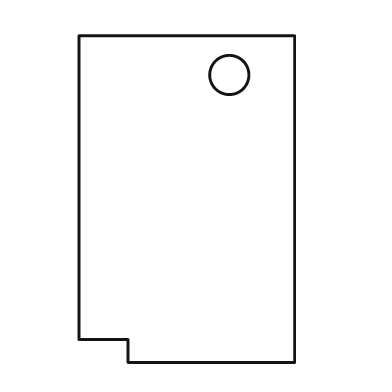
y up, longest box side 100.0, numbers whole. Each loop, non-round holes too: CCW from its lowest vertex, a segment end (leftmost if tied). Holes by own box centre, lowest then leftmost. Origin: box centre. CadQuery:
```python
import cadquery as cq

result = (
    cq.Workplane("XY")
    .moveTo(-18.0, -50.0)
    .lineTo(33.0, -50.0)
    .lineTo(33.0, 50.0)
    .lineTo(-33.0, 50.0)
    .lineTo(-33.0, -43.0)
    .lineTo(-18.0, -43.0)
    .close()
    .moveTo(13.0, 38.0)
    .circle(6.0)
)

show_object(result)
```